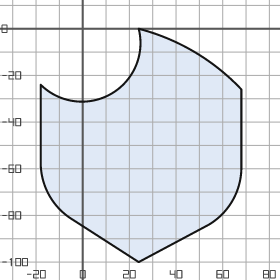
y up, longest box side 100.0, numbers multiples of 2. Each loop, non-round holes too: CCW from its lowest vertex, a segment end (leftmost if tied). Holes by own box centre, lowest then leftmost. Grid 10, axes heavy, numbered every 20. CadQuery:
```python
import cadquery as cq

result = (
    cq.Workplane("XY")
    .moveTo(24.0, -100.0)
    .lineTo(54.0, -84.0)
    .threePointArc((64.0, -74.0), (68.0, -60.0))
    .lineTo(68.0, -26.0)
    .threePointArc((48.0, -10.0), (24.0, 0.0))
    .threePointArc((12.0, -28.0), (-18.0, -24.0))
    .lineTo(-18.0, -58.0)
    .threePointArc((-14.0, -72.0), (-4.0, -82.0))
    .close()
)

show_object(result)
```